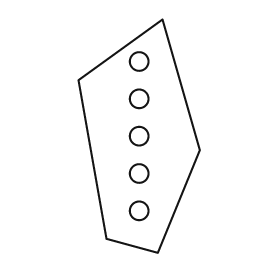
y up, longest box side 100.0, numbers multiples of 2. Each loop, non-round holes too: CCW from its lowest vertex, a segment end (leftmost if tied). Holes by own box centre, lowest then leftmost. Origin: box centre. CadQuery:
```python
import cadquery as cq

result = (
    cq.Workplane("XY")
    .moveTo(8.0, -50.0)
    .lineTo(26.0, -6.0)
    .lineTo(10.0, 50.0)
    .lineTo(-26.0, 24.0)
    .lineTo(-14.0, -44.0)
    .close()
    .moveTo(0.0, -32.0)
    .circle(4.0)
    .moveTo(0.0, -16.0)
    .circle(4.0)
    .moveTo(0.0, 0.0)
    .circle(4.0)
    .moveTo(0.0, 16.0)
    .circle(4.0)
    .moveTo(0.0, 32.0)
    .circle(4.0)
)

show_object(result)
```